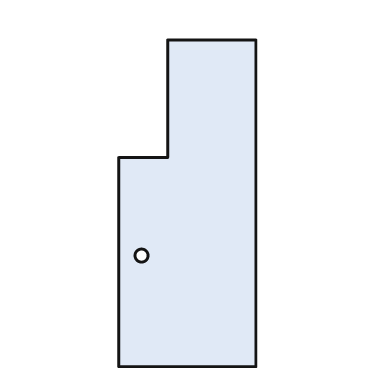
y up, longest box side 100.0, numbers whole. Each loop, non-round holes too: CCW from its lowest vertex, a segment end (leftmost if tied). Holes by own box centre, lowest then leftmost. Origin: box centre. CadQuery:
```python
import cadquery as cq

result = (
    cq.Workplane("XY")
    .moveTo(-21.0, -50.0)
    .lineTo(21.0, -50.0)
    .lineTo(21.0, 50.0)
    .lineTo(-6.0, 50.0)
    .lineTo(-6.0, 14.0)
    .lineTo(-21.0, 14.0)
    .close()
    .moveTo(-14.0, -16.0)
    .circle(2.0)
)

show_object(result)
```